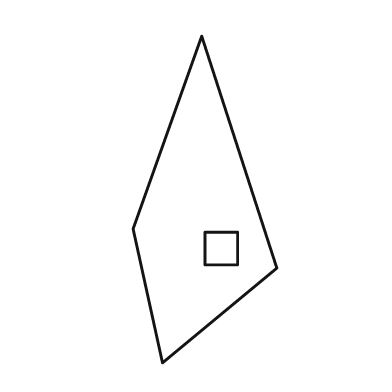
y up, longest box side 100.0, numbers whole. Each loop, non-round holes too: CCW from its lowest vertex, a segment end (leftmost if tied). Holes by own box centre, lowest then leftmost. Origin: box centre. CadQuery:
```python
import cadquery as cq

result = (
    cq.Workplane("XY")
    .moveTo(-13.0, -50.0)
    .lineTo(22.0, -21.0)
    .lineTo(-1.0, 50.0)
    .lineTo(-22.0, -9.0)
    .close()
    .moveTo(0.0, -20.0)
    .lineTo(10.0, -20.0)
    .lineTo(10.0, -10.0)
    .lineTo(0.0, -10.0)
    .close()
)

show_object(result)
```